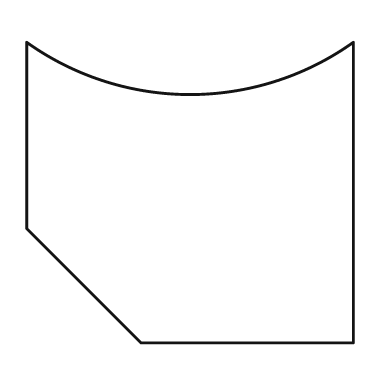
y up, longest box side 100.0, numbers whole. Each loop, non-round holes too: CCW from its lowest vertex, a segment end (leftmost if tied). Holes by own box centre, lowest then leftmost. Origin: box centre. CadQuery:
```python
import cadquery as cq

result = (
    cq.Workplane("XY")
    .moveTo(-15.0, -46.0)
    .lineTo(50.0, -46.0)
    .lineTo(50.0, 46.0)
    .threePointArc((0.0, 30.0), (-50.0, 46.0))
    .lineTo(-50.0, -11.0)
    .close()
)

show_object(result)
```